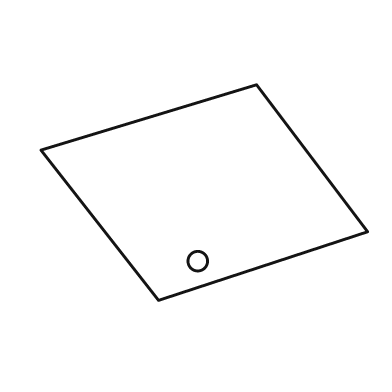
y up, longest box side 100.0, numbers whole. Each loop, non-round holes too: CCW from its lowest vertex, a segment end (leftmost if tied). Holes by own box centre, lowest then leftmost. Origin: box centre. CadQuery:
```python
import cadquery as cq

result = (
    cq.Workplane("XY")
    .moveTo(-14.0, -33.0)
    .lineTo(50.0, -12.0)
    .lineTo(16.0, 33.0)
    .lineTo(-50.0, 13.0)
    .close()
    .moveTo(-2.0, -21.0)
    .circle(3.0)
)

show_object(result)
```